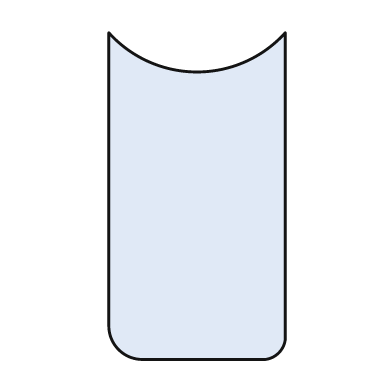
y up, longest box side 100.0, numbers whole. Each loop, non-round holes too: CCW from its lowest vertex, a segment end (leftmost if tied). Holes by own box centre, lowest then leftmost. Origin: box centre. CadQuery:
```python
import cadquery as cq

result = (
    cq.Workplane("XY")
    .moveTo(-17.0, -50.0)
    .lineTo(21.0, -50.0)
    .threePointArc((25.0, -48.0), (27.0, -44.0))
    .lineTo(27.0, 50.0)
    .threePointArc((0.0, 38.0), (-27.0, 50.0))
    .lineTo(-27.0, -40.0)
    .threePointArc((-24.0, -47.0), (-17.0, -50.0))
    .close()
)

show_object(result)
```